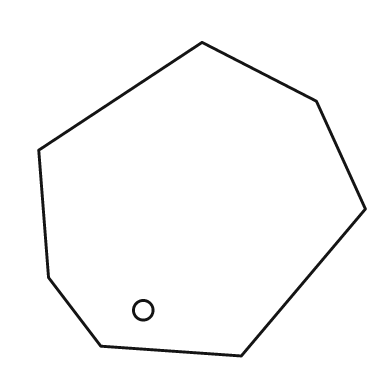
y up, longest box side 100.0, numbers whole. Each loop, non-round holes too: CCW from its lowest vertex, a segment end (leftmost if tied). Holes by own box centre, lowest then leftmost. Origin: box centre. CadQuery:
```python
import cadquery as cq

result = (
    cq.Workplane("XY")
    .moveTo(12.0, -48.0)
    .lineTo(50.0, -3.0)
    .lineTo(35.0, 30.0)
    .lineTo(0.0, 48.0)
    .lineTo(-50.0, 15.0)
    .lineTo(-47.0, -24.0)
    .lineTo(-31.0, -45.0)
    .close()
    .moveTo(-18.0, -34.0)
    .circle(3.0)
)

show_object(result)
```